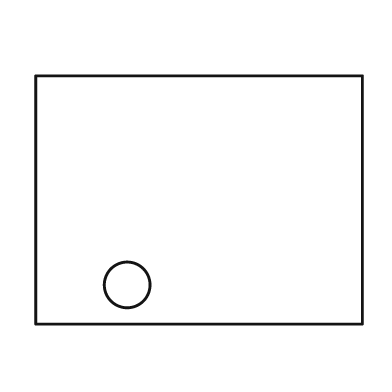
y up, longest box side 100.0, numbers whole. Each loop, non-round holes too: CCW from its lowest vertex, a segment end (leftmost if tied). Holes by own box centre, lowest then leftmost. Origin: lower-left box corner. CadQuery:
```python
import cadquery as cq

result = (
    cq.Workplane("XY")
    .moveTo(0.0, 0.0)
    .lineTo(100.0, 0.0)
    .lineTo(100.0, 76.0)
    .lineTo(0.0, 76.0)
    .close()
    .moveTo(28.0, 12.0)
    .circle(7.0)
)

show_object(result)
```